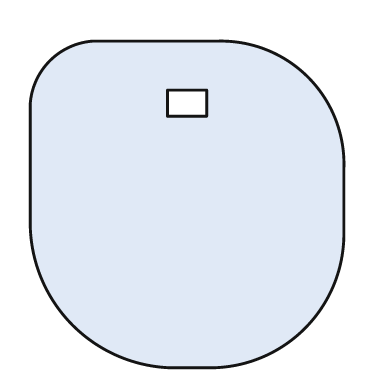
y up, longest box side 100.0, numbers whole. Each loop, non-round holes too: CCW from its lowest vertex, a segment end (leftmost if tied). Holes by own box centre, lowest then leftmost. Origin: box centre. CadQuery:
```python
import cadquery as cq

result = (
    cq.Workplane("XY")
    .moveTo(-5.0, -50.0)
    .lineTo(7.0, -50.0)
    .threePointArc((36.0, -38.0), (48.0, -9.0))
    .lineTo(48.0, 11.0)
    .threePointArc((37.0, 39.0), (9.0, 50.0))
    .lineTo(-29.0, 50.0)
    .threePointArc((-42.0, 44.0), (-48.0, 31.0))
    .lineTo(-48.0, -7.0)
    .threePointArc((-35.0, -37.0), (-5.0, -50.0))
    .close()
    .moveTo(-6.0, 27.0)
    .lineTo(6.0, 27.0)
    .lineTo(6.0, 35.0)
    .lineTo(-6.0, 35.0)
    .close()
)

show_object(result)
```